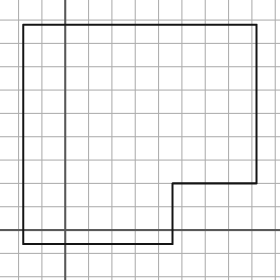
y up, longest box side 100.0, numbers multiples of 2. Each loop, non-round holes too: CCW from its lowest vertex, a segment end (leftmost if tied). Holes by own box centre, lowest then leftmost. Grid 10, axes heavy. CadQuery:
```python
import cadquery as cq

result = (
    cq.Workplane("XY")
    .moveTo(-18.0, -6.0)
    .lineTo(46.0, -6.0)
    .lineTo(46.0, 20.0)
    .lineTo(82.0, 20.0)
    .lineTo(82.0, 88.0)
    .lineTo(-18.0, 88.0)
    .close()
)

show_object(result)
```